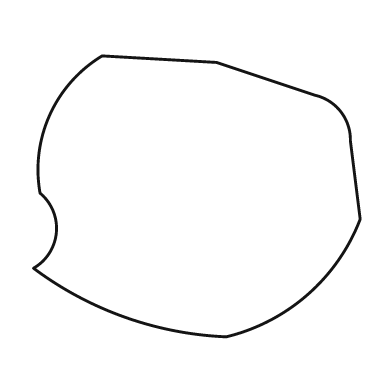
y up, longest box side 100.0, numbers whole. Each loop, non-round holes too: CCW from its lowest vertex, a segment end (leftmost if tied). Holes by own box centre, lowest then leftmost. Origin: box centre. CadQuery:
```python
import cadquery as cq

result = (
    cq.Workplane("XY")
    .moveTo(9.0, -43.0)
    .threePointArc((34.0, -30.0), (50.0, -7.0))
    .lineTo(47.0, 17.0)
    .threePointArc((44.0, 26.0), (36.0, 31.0))
    .lineTo(6.0, 41.0)
    .lineTo(-29.0, 43.0)
    .threePointArc((-45.0, 25.0), (-48.0, 1.0))
    .threePointArc((-43.0, -11.0), (-50.0, -22.0))
    .threePointArc((-22.0, -37.0), (9.0, -43.0))
    .close()
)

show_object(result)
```